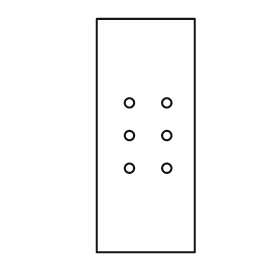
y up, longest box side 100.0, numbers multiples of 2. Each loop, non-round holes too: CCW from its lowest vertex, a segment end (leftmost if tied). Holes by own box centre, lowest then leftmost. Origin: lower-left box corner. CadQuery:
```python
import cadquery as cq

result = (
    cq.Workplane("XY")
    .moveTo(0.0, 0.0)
    .lineTo(42.0, 0.0)
    .lineTo(42.0, 100.0)
    .lineTo(0.0, 100.0)
    .close()
    .moveTo(14.0, 36.0)
    .circle(2.0)
    .moveTo(30.0, 36.0)
    .circle(2.0)
    .moveTo(14.0, 50.0)
    .circle(2.0)
    .moveTo(30.0, 50.0)
    .circle(2.0)
    .moveTo(14.0, 64.0)
    .circle(2.0)
    .moveTo(30.0, 64.0)
    .circle(2.0)
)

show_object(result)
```